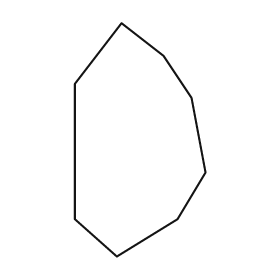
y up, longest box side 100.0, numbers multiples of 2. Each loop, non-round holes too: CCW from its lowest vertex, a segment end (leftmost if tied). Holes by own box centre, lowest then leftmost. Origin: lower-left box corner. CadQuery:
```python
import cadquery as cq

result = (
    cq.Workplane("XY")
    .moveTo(18.0, 0.0)
    .lineTo(44.0, 16.0)
    .lineTo(56.0, 36.0)
    .lineTo(50.0, 68.0)
    .lineTo(38.0, 86.0)
    .lineTo(20.0, 100.0)
    .lineTo(0.0, 74.0)
    .lineTo(0.0, 16.0)
    .close()
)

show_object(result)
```